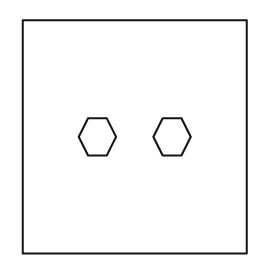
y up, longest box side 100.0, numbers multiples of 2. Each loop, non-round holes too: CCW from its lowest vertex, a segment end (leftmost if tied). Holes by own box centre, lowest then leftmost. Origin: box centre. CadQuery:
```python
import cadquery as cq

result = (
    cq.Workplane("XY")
    .moveTo(-48.0, -50.0)
    .lineTo(48.0, -50.0)
    .lineTo(48.0, 50.0)
    .lineTo(-48.0, 50.0)
    .close()
    .moveTo(-20.0, -8.0)
    .lineTo(-12.0, -8.0)
    .lineTo(-8.0, 0.0)
    .lineTo(-12.0, 8.0)
    .lineTo(-20.0, 8.0)
    .lineTo(-24.0, 0.0)
    .close()
    .moveTo(12.0, -8.0)
    .lineTo(20.0, -8.0)
    .lineTo(24.0, 0.0)
    .lineTo(20.0, 8.0)
    .lineTo(12.0, 8.0)
    .lineTo(8.0, 0.0)
    .close()
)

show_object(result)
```